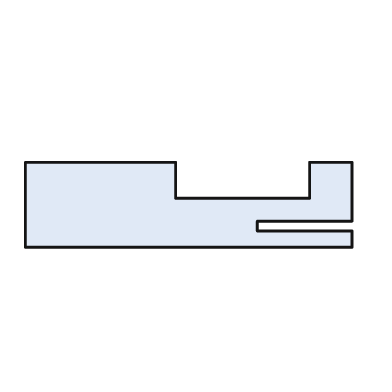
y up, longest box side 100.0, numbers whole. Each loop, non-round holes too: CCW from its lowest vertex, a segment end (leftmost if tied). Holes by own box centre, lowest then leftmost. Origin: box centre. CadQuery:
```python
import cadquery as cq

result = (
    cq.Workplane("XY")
    .moveTo(-50.0, -13.0)
    .lineTo(50.0, -13.0)
    .lineTo(50.0, -8.0)
    .lineTo(21.0, -8.0)
    .lineTo(21.0, -5.0)
    .lineTo(50.0, -5.0)
    .lineTo(50.0, 13.0)
    .lineTo(37.0, 13.0)
    .lineTo(37.0, 2.0)
    .lineTo(-4.0, 2.0)
    .lineTo(-4.0, 13.0)
    .lineTo(-50.0, 13.0)
    .close()
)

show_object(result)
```